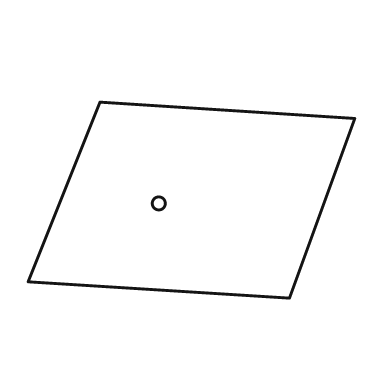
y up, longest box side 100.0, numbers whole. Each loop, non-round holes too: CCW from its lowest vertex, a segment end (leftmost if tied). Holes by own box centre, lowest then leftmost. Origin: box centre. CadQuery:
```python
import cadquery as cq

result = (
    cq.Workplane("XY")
    .moveTo(30.0, -30.0)
    .lineTo(50.0, 25.0)
    .lineTo(-28.0, 30.0)
    .lineTo(-50.0, -25.0)
    .close()
    .moveTo(-10.0, -1.0)
    .circle(2.0)
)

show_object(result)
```